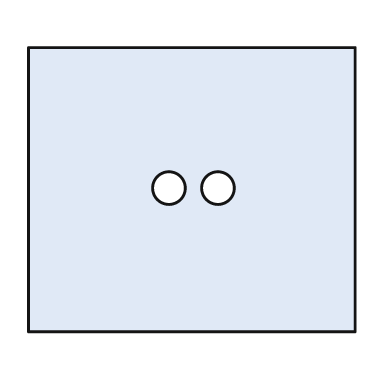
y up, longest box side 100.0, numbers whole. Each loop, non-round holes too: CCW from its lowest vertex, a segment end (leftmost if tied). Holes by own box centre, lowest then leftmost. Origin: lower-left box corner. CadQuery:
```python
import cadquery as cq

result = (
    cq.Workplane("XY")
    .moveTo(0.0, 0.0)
    .lineTo(100.0, 0.0)
    .lineTo(100.0, 87.0)
    .lineTo(0.0, 87.0)
    .close()
    .moveTo(43.0, 44.0)
    .circle(5.0)
    .moveTo(58.0, 44.0)
    .circle(5.0)
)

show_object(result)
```